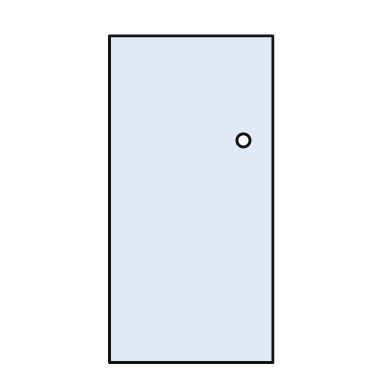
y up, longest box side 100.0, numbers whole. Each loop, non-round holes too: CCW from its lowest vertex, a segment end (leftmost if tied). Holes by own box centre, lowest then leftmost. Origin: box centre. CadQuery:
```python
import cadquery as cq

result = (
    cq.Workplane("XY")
    .moveTo(-25.0, -50.0)
    .lineTo(25.0, -50.0)
    .lineTo(25.0, 50.0)
    .lineTo(-25.0, 50.0)
    .close()
    .moveTo(16.0, 18.0)
    .circle(2.0)
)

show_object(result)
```